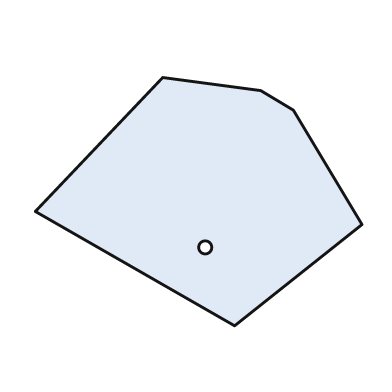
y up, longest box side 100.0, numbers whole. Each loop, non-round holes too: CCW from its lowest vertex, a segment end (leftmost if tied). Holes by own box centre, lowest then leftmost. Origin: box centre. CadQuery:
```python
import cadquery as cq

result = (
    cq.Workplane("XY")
    .moveTo(11.0, -38.0)
    .lineTo(50.0, -7.0)
    .lineTo(29.0, 28.0)
    .lineTo(19.0, 34.0)
    .lineTo(-11.0, 38.0)
    .lineTo(-50.0, -3.0)
    .close()
    .moveTo(2.0, -14.0)
    .circle(2.0)
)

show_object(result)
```